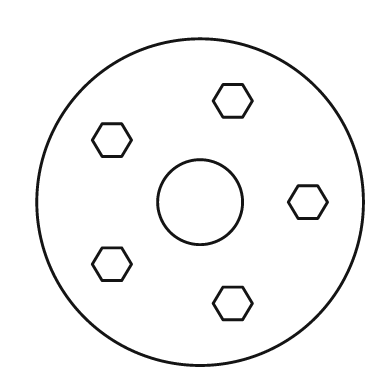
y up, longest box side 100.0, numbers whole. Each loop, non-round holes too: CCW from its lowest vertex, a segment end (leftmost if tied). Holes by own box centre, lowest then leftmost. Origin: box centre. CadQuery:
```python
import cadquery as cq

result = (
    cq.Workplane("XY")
    .moveTo(0.0, 0.0)
    .circle(50.0)
    .moveTo(7.0, -36.0)
    .lineTo(13.0, -36.0)
    .lineTo(16.0, -31.0)
    .lineTo(13.0, -26.0)
    .lineTo(7.0, -26.0)
    .lineTo(4.0, -31.0)
    .close()
    .moveTo(-30.0, -24.0)
    .lineTo(-24.0, -24.0)
    .lineTo(-21.0, -19.0)
    .lineTo(-24.0, -14.0)
    .lineTo(-30.0, -14.0)
    .lineTo(-33.0, -19.0)
    .close()
    .moveTo(0.0, 0.0)
    .circle(13.0)
    .moveTo(30.0, -5.0)
    .lineTo(36.0, -5.0)
    .lineTo(39.0, 0.0)
    .lineTo(36.0, 5.0)
    .lineTo(30.0, 5.0)
    .lineTo(27.0, 0.0)
    .close()
    .moveTo(-30.0, 14.0)
    .lineTo(-24.0, 14.0)
    .lineTo(-21.0, 19.0)
    .lineTo(-24.0, 24.0)
    .lineTo(-30.0, 24.0)
    .lineTo(-33.0, 19.0)
    .close()
    .moveTo(7.0, 26.0)
    .lineTo(13.0, 26.0)
    .lineTo(16.0, 31.0)
    .lineTo(13.0, 36.0)
    .lineTo(7.0, 36.0)
    .lineTo(4.0, 31.0)
    .close()
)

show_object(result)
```